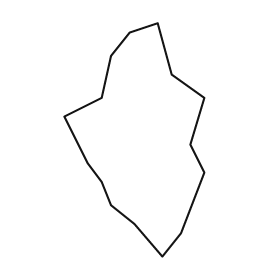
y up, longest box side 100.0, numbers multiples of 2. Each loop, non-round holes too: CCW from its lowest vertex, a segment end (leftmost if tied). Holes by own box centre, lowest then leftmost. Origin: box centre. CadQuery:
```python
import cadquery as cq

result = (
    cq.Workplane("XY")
    .moveTo(12.0, -50.0)
    .lineTo(20.0, -40.0)
    .lineTo(30.0, -14.0)
    .lineTo(24.0, -2.0)
    .lineTo(30.0, 18.0)
    .lineTo(16.0, 28.0)
    .lineTo(10.0, 50.0)
    .lineTo(-2.0, 46.0)
    .lineTo(-10.0, 36.0)
    .lineTo(-14.0, 18.0)
    .lineTo(-30.0, 10.0)
    .lineTo(-20.0, -10.0)
    .lineTo(-14.0, -18.0)
    .lineTo(-10.0, -28.0)
    .lineTo(0.0, -36.0)
    .close()
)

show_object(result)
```